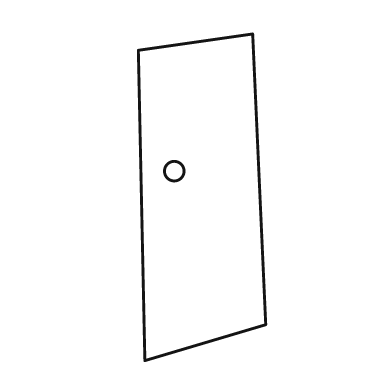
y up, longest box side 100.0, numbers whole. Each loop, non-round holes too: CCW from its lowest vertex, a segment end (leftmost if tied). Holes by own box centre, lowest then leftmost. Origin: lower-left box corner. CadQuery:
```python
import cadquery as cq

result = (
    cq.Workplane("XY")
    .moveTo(2.0, 0.0)
    .lineTo(39.0, 11.0)
    .lineTo(35.0, 100.0)
    .lineTo(0.0, 95.0)
    .close()
    .moveTo(11.0, 58.0)
    .circle(3.0)
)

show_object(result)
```